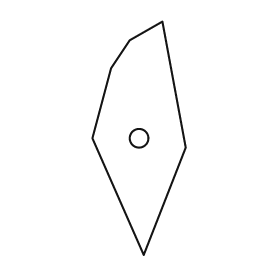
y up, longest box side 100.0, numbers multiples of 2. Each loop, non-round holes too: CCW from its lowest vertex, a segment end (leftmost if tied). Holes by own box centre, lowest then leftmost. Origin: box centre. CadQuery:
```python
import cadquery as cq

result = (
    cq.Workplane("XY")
    .moveTo(2.0, -50.0)
    .lineTo(20.0, -4.0)
    .lineTo(10.0, 50.0)
    .lineTo(-4.0, 42.0)
    .lineTo(-12.0, 30.0)
    .lineTo(-20.0, 0.0)
    .close()
    .moveTo(0.0, 0.0)
    .circle(4.0)
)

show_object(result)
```